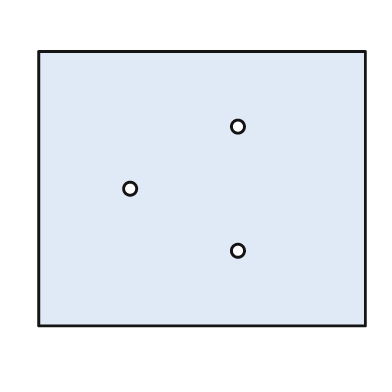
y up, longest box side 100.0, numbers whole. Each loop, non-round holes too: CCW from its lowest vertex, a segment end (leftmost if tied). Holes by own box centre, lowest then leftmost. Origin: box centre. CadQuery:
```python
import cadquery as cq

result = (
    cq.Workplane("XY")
    .moveTo(-50.0, -42.0)
    .lineTo(50.0, -42.0)
    .lineTo(50.0, 42.0)
    .lineTo(-50.0, 42.0)
    .close()
    .moveTo(11.0, -19.0)
    .circle(2.0)
    .moveTo(-22.0, 0.0)
    .circle(2.0)
    .moveTo(11.0, 19.0)
    .circle(2.0)
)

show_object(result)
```